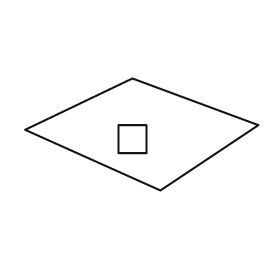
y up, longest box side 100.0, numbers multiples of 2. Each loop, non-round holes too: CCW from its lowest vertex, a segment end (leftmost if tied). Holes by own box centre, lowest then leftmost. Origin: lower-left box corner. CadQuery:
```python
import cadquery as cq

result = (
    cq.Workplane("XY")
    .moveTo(58.0, 0.0)
    .lineTo(100.0, 28.0)
    .lineTo(46.0, 48.0)
    .lineTo(0.0, 26.0)
    .close()
    .moveTo(40.0, 16.0)
    .lineTo(52.0, 16.0)
    .lineTo(52.0, 28.0)
    .lineTo(40.0, 28.0)
    .close()
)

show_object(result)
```